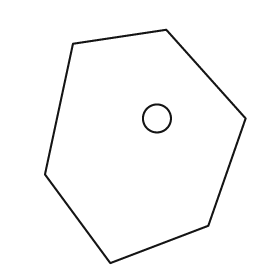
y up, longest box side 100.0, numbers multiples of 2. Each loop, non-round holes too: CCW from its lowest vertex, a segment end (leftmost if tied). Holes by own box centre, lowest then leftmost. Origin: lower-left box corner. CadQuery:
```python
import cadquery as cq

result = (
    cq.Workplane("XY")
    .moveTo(28.0, 0.0)
    .lineTo(70.0, 16.0)
    .lineTo(86.0, 62.0)
    .lineTo(52.0, 100.0)
    .lineTo(12.0, 94.0)
    .lineTo(0.0, 38.0)
    .close()
    .moveTo(48.0, 62.0)
    .circle(6.0)
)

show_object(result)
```